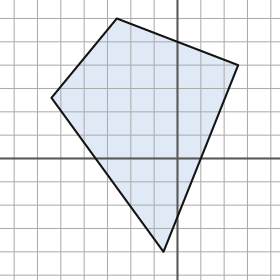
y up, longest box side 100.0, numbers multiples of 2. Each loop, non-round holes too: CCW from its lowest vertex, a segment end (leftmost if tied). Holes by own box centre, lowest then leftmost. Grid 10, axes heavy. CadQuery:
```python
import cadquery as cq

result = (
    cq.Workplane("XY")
    .moveTo(-6.0, -40.0)
    .lineTo(26.0, 40.0)
    .lineTo(-26.0, 60.0)
    .lineTo(-54.0, 26.0)
    .close()
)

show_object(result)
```